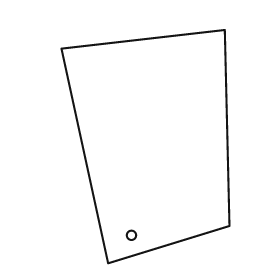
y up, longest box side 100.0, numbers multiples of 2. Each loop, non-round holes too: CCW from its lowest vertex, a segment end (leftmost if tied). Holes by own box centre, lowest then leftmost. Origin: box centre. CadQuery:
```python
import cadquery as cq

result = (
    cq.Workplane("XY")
    .moveTo(-16.0, -50.0)
    .lineTo(36.0, -34.0)
    .lineTo(34.0, 50.0)
    .lineTo(-36.0, 42.0)
    .close()
    .moveTo(-6.0, -38.0)
    .circle(2.0)
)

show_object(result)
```